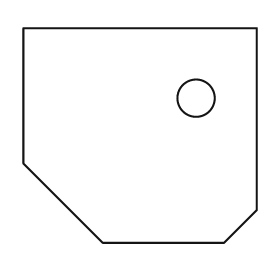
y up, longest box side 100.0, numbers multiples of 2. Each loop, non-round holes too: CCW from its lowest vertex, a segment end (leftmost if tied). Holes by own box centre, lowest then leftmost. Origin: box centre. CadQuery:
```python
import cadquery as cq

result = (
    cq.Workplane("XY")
    .moveTo(-16.0, -46.0)
    .lineTo(36.0, -46.0)
    .lineTo(50.0, -32.0)
    .lineTo(50.0, 46.0)
    .lineTo(-50.0, 46.0)
    .lineTo(-50.0, -12.0)
    .close()
    .moveTo(24.0, 16.0)
    .circle(8.0)
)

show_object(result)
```